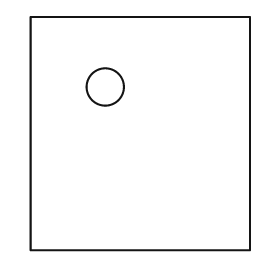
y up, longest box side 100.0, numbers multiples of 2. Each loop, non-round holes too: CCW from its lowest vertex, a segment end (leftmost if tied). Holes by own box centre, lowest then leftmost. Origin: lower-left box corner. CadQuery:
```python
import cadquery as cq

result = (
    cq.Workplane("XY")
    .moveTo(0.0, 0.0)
    .lineTo(94.0, 0.0)
    .lineTo(94.0, 100.0)
    .lineTo(0.0, 100.0)
    .close()
    .moveTo(32.0, 70.0)
    .circle(8.0)
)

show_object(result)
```